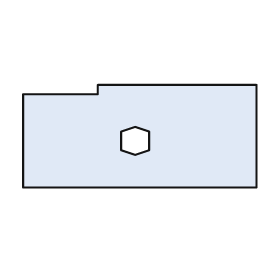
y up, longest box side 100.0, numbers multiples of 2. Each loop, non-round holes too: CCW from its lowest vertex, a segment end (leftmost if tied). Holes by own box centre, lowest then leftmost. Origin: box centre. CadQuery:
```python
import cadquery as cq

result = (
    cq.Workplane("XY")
    .moveTo(-50.0, -22.0)
    .lineTo(50.0, -22.0)
    .lineTo(50.0, 22.0)
    .lineTo(-18.0, 22.0)
    .lineTo(-18.0, 18.0)
    .lineTo(-50.0, 18.0)
    .close()
    .moveTo(-2.0, -8.0)
    .lineTo(4.0, -6.0)
    .lineTo(4.0, 2.0)
    .lineTo(-2.0, 4.0)
    .lineTo(-8.0, 2.0)
    .lineTo(-8.0, -6.0)
    .close()
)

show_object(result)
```